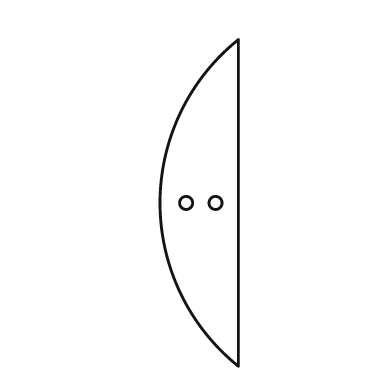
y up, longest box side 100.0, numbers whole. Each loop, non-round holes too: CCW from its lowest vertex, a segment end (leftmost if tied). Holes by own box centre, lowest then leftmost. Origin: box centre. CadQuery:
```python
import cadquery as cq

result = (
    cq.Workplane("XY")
    .moveTo(12.0, -50.0)
    .lineTo(12.0, 50.0)
    .threePointArc((-12.0, 0.0), (12.0, -50.0))
    .close()
    .moveTo(-4.0, 0.0)
    .circle(2.0)
    .moveTo(5.0, 0.0)
    .circle(2.0)
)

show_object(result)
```